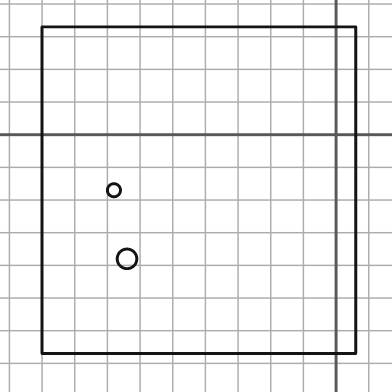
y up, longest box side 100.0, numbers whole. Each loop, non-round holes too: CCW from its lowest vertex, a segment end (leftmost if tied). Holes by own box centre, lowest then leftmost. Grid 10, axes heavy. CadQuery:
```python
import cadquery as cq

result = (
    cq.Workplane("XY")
    .moveTo(-90.0, -67.0)
    .lineTo(6.0, -67.0)
    .lineTo(6.0, 33.0)
    .lineTo(-90.0, 33.0)
    .close()
    .moveTo(-64.0, -38.0)
    .circle(3.0)
    .moveTo(-68.0, -17.0)
    .circle(2.0)
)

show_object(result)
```